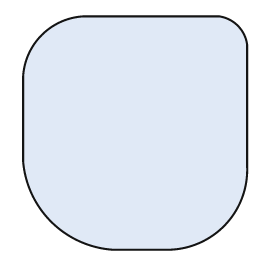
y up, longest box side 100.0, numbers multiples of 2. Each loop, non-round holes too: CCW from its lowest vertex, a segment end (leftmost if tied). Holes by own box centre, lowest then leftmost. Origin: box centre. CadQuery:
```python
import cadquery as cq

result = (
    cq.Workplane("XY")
    .moveTo(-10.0, -50.0)
    .lineTo(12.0, -50.0)
    .threePointArc((38.0, -40.0), (48.0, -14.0))
    .lineTo(48.0, 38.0)
    .threePointArc((44.0, 46.0), (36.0, 50.0))
    .lineTo(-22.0, 50.0)
    .threePointArc((-40.0, 42.0), (-48.0, 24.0))
    .lineTo(-48.0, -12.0)
    .threePointArc((-36.0, -38.0), (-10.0, -50.0))
    .close()
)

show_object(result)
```